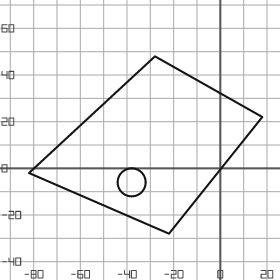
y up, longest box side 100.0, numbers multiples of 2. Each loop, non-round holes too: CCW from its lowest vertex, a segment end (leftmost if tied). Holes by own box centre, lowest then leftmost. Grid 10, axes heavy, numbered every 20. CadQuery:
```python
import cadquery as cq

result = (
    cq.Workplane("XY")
    .moveTo(-22.0, -28.0)
    .lineTo(18.0, 22.0)
    .lineTo(-28.0, 48.0)
    .lineTo(-82.0, -2.0)
    .close()
    .moveTo(-38.0, -6.0)
    .circle(6.0)
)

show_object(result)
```